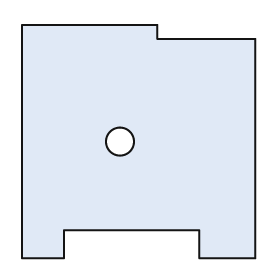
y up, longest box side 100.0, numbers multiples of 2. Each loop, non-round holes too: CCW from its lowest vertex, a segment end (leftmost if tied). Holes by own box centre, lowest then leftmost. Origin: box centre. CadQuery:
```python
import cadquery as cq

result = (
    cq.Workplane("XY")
    .moveTo(-50.0, -50.0)
    .lineTo(-32.0, -50.0)
    .lineTo(-32.0, -38.0)
    .lineTo(26.0, -38.0)
    .lineTo(26.0, -50.0)
    .lineTo(50.0, -50.0)
    .lineTo(50.0, 44.0)
    .lineTo(8.0, 44.0)
    .lineTo(8.0, 50.0)
    .lineTo(-50.0, 50.0)
    .close()
    .moveTo(-8.0, 0.0)
    .circle(6.0)
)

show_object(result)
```